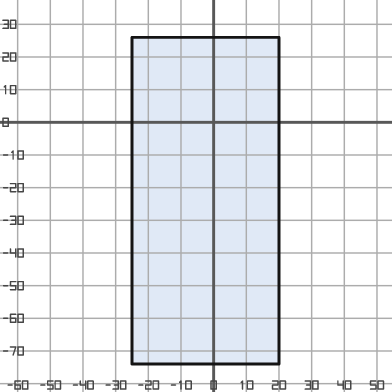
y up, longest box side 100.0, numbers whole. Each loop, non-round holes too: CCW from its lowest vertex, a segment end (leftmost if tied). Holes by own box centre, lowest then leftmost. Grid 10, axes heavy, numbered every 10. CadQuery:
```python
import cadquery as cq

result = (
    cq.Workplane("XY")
    .moveTo(-25.0, -74.0)
    .lineTo(20.0, -74.0)
    .lineTo(20.0, 26.0)
    .lineTo(-25.0, 26.0)
    .close()
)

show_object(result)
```